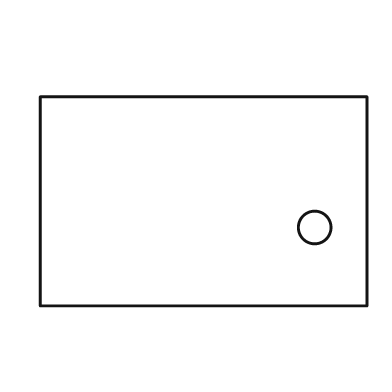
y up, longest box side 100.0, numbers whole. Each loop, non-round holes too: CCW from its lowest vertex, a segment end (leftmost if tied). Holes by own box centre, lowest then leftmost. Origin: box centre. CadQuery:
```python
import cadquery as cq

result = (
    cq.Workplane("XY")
    .moveTo(-50.0, -32.0)
    .lineTo(50.0, -32.0)
    .lineTo(50.0, 32.0)
    .lineTo(-50.0, 32.0)
    .close()
    .moveTo(34.0, -8.0)
    .circle(5.0)
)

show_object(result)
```